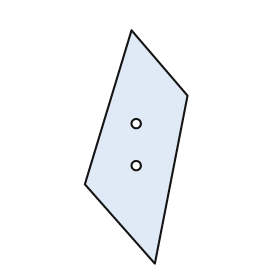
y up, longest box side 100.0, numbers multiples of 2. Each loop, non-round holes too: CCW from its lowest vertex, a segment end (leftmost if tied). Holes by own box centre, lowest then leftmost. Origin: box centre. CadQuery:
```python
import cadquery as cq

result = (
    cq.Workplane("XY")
    .moveTo(8.0, -50.0)
    .lineTo(22.0, 22.0)
    .lineTo(-2.0, 50.0)
    .lineTo(-22.0, -16.0)
    .close()
    .moveTo(0.0, -8.0)
    .circle(2.0)
    .moveTo(0.0, 10.0)
    .circle(2.0)
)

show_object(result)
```